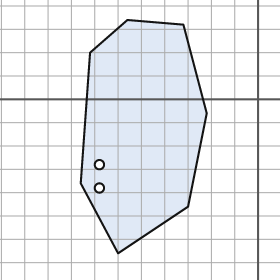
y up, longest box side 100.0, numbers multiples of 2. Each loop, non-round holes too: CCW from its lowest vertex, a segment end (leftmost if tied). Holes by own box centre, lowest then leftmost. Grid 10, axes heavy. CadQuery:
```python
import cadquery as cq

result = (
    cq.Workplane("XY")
    .moveTo(-60.0, -66.0)
    .lineTo(-30.0, -46.0)
    .lineTo(-22.0, -6.0)
    .lineTo(-32.0, 32.0)
    .lineTo(-56.0, 34.0)
    .lineTo(-72.0, 20.0)
    .lineTo(-76.0, -36.0)
    .close()
    .moveTo(-68.0, -38.0)
    .circle(2.0)
    .moveTo(-68.0, -28.0)
    .circle(2.0)
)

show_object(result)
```